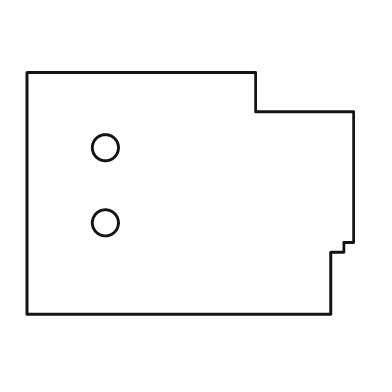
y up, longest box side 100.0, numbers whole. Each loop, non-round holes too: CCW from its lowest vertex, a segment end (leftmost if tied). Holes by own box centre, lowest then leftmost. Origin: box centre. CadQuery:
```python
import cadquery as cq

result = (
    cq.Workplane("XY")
    .moveTo(-50.0, -37.0)
    .lineTo(43.0, -37.0)
    .lineTo(43.0, -18.0)
    .lineTo(47.0, -18.0)
    .lineTo(47.0, -15.0)
    .lineTo(50.0, -15.0)
    .lineTo(50.0, 25.0)
    .lineTo(20.0, 25.0)
    .lineTo(20.0, 37.0)
    .lineTo(-50.0, 37.0)
    .close()
    .moveTo(-26.0, -9.0)
    .circle(4.0)
    .moveTo(-26.0, 14.0)
    .circle(4.0)
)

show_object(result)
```